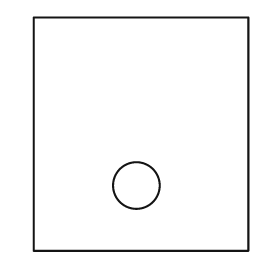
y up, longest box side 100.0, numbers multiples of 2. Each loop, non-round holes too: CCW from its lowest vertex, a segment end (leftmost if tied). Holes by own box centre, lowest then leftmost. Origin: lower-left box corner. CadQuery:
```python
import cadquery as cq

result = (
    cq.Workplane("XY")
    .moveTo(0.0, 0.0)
    .lineTo(92.0, 0.0)
    .lineTo(92.0, 100.0)
    .lineTo(0.0, 100.0)
    .close()
    .moveTo(44.0, 28.0)
    .circle(10.0)
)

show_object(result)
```